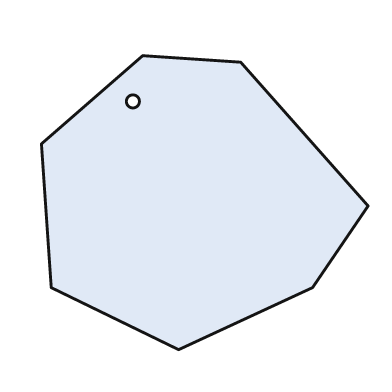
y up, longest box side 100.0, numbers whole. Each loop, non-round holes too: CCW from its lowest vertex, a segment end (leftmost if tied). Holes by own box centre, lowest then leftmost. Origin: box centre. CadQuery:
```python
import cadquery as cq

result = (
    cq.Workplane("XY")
    .moveTo(-8.0, -45.0)
    .lineTo(33.0, -26.0)
    .lineTo(50.0, -1.0)
    .lineTo(11.0, 43.0)
    .lineTo(-19.0, 45.0)
    .lineTo(-50.0, 18.0)
    .lineTo(-47.0, -26.0)
    .close()
    .moveTo(-22.0, 31.0)
    .circle(2.0)
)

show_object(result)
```